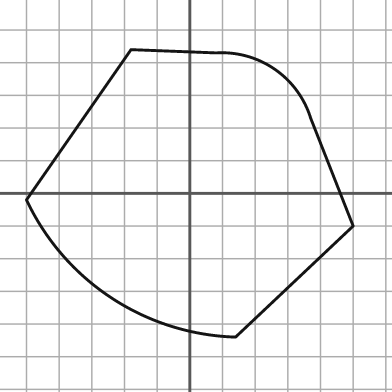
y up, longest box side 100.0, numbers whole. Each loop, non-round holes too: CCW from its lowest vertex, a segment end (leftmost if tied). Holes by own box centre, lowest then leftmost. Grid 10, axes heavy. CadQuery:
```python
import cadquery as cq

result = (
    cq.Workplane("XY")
    .moveTo(14.0, -44.0)
    .lineTo(50.0, -10.0)
    .lineTo(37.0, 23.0)
    .threePointArc((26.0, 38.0), (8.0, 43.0))
    .lineTo(-18.0, 44.0)
    .lineTo(-50.0, -2.0)
    .threePointArc((-24.0, -32.0), (14.0, -44.0))
    .close()
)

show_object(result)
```